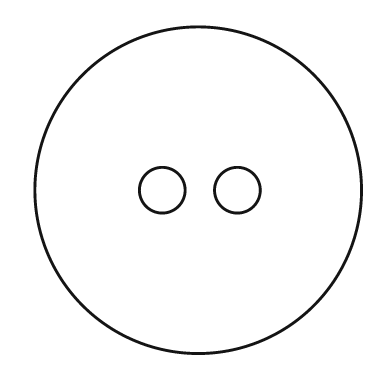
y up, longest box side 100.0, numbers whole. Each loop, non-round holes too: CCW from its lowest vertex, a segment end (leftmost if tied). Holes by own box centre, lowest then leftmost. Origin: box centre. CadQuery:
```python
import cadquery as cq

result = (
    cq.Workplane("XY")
    .moveTo(0.0, 0.0)
    .circle(50.0)
    .moveTo(-11.0, 0.0)
    .circle(7.0)
    .moveTo(12.0, 0.0)
    .circle(7.0)
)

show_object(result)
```